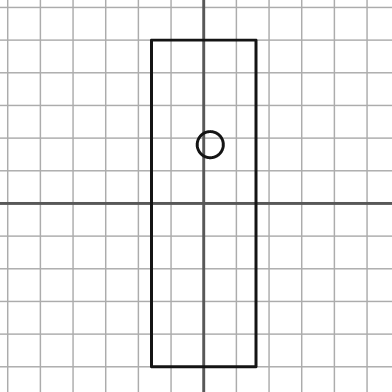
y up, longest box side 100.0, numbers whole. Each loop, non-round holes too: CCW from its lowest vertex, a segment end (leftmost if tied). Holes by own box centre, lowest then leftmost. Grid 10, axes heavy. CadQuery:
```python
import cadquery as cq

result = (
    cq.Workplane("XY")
    .moveTo(-16.0, -50.0)
    .lineTo(16.0, -50.0)
    .lineTo(16.0, 50.0)
    .lineTo(-16.0, 50.0)
    .close()
    .moveTo(2.0, 18.0)
    .circle(4.0)
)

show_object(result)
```